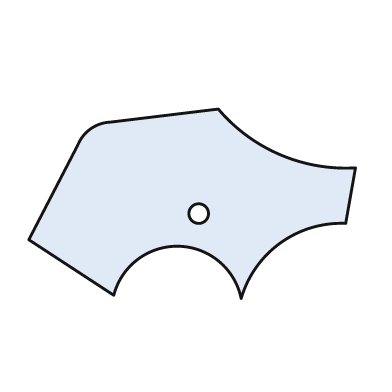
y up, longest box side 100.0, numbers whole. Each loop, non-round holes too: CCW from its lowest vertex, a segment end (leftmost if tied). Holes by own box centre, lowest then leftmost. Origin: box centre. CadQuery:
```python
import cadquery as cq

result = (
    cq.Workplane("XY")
    .moveTo(15.0, -29.0)
    .threePointArc((27.0, -12.0), (47.0, -6.0))
    .lineTo(50.0, 11.0)
    .threePointArc((27.0, 15.0), (8.0, 29.0))
    .lineTo(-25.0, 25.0)
    .threePointArc((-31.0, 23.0), (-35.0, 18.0))
    .lineTo(-50.0, -11.0)
    .lineTo(-24.0, -28.0)
    .threePointArc((-4.0, -13.0), (15.0, -29.0))
    .close()
    .moveTo(2.0, -3.0)
    .circle(3.0)
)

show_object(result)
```